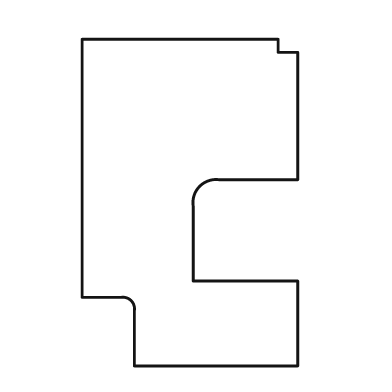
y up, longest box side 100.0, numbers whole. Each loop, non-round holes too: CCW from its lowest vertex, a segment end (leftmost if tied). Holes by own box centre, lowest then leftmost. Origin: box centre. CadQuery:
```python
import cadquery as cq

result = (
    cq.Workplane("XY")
    .moveTo(-17.0, -50.0)
    .lineTo(33.0, -50.0)
    .lineTo(33.0, -24.0)
    .lineTo(1.0, -24.0)
    .lineTo(1.0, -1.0)
    .threePointArc((3.0, 5.0), (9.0, 7.0))
    .lineTo(33.0, 7.0)
    .lineTo(33.0, 46.0)
    .lineTo(27.0, 46.0)
    .lineTo(27.0, 50.0)
    .lineTo(-33.0, 50.0)
    .lineTo(-33.0, -29.0)
    .lineTo(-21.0, -29.0)
    .threePointArc((-18.0, -30.0), (-17.0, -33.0))
    .close()
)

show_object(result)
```